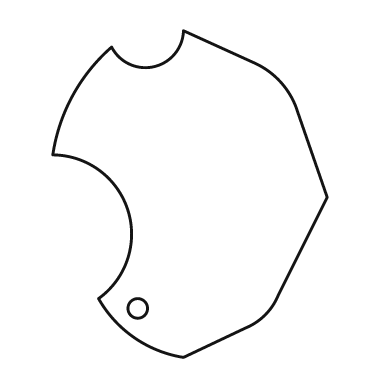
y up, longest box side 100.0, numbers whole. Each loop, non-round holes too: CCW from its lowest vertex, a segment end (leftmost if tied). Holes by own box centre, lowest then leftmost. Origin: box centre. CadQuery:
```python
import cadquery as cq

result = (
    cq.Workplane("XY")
    .moveTo(-2.0, -50.0)
    .lineTo(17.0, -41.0)
    .threePointArc((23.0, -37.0), (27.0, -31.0))
    .lineTo(42.0, -1.0)
    .lineTo(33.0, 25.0)
    .threePointArc((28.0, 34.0), (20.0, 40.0))
    .lineTo(-2.0, 50.0)
    .threePointArc((-11.0, 39.0), (-24.0, 45.0))
    .threePointArc((-36.0, 30.0), (-42.0, 12.0))
    .threePointArc((-19.0, -5.0), (-28.0, -32.0))
    .threePointArc((-17.0, -44.0), (-2.0, -50.0))
    .close()
    .moveTo(-16.0, -35.0)
    .circle(3.0)
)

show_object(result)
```